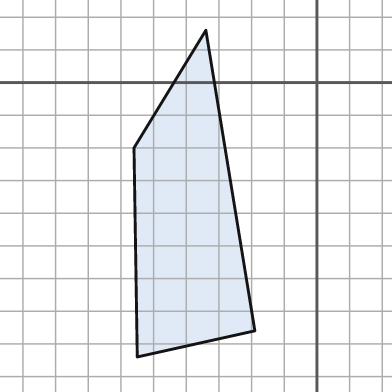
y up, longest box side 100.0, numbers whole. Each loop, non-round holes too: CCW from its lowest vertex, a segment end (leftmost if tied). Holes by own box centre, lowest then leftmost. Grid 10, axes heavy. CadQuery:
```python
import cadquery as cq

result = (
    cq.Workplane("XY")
    .moveTo(-55.0, -84.0)
    .lineTo(-19.0, -76.0)
    .lineTo(-34.0, 16.0)
    .lineTo(-56.0, -20.0)
    .close()
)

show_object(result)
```